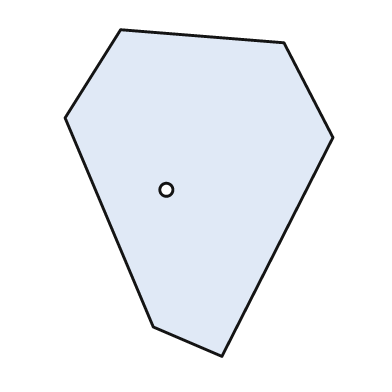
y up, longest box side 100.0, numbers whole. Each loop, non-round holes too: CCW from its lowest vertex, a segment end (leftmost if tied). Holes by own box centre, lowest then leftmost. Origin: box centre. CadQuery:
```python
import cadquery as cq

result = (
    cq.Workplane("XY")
    .moveTo(7.0, -50.0)
    .lineTo(41.0, 17.0)
    .lineTo(26.0, 46.0)
    .lineTo(-24.0, 50.0)
    .lineTo(-41.0, 23.0)
    .lineTo(-14.0, -41.0)
    .close()
    .moveTo(-10.0, 1.0)
    .circle(2.0)
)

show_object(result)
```